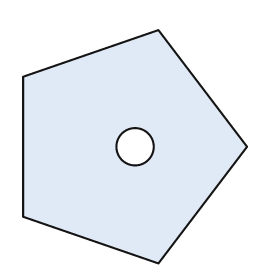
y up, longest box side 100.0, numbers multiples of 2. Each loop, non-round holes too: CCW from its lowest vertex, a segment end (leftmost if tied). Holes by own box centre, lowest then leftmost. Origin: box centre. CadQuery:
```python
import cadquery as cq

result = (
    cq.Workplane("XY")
    .moveTo(10.0, -50.0)
    .lineTo(48.0, 0.0)
    .lineTo(10.0, 50.0)
    .lineTo(-48.0, 30.0)
    .lineTo(-48.0, -30.0)
    .close()
    .moveTo(0.0, 0.0)
    .circle(8.0)
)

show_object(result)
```